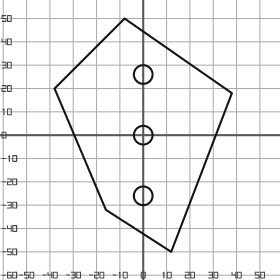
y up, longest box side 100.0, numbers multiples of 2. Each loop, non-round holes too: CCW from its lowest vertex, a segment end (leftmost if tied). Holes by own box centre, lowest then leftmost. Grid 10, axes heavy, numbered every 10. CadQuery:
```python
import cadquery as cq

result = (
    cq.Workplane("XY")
    .moveTo(12.0, -50.0)
    .lineTo(38.0, 18.0)
    .lineTo(-8.0, 50.0)
    .lineTo(-38.0, 20.0)
    .lineTo(-16.0, -32.0)
    .close()
    .moveTo(0.0, -26.0)
    .circle(4.0)
    .moveTo(0.0, 0.0)
    .circle(4.0)
    .moveTo(0.0, 26.0)
    .circle(4.0)
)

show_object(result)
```